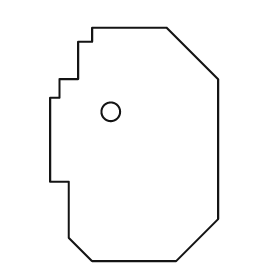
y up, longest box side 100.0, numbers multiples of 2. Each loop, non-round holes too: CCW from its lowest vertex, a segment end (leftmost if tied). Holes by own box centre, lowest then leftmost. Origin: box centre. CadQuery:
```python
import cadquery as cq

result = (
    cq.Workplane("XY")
    .moveTo(-18.0, -50.0)
    .lineTo(18.0, -50.0)
    .lineTo(36.0, -32.0)
    .lineTo(36.0, 28.0)
    .lineTo(14.0, 50.0)
    .lineTo(-18.0, 50.0)
    .lineTo(-18.0, 44.0)
    .lineTo(-24.0, 44.0)
    .lineTo(-24.0, 28.0)
    .lineTo(-32.0, 28.0)
    .lineTo(-32.0, 20.0)
    .lineTo(-36.0, 20.0)
    .lineTo(-36.0, -16.0)
    .lineTo(-28.0, -16.0)
    .lineTo(-28.0, -40.0)
    .close()
    .moveTo(-10.0, 14.0)
    .circle(4.0)
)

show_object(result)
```